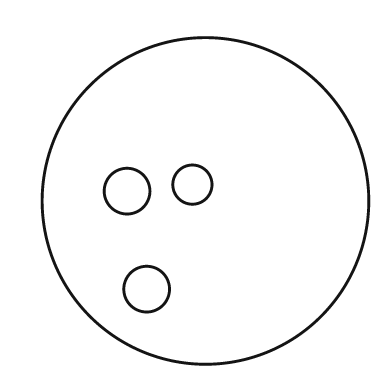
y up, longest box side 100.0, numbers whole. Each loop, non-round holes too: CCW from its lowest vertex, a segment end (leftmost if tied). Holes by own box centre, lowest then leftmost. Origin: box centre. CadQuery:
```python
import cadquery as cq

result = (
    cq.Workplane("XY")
    .moveTo(0.0, 0.0)
    .circle(50.0)
    .moveTo(-18.0, -27.0)
    .circle(7.0)
    .moveTo(-24.0, 3.0)
    .circle(7.0)
    .moveTo(-4.0, 5.0)
    .circle(6.0)
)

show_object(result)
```